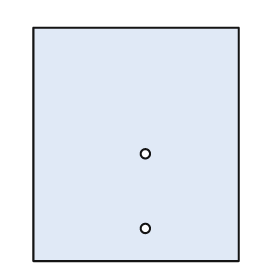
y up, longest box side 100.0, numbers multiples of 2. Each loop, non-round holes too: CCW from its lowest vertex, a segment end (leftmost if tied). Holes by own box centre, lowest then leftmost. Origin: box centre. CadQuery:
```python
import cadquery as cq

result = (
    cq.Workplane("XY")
    .moveTo(-44.0, -50.0)
    .lineTo(44.0, -50.0)
    .lineTo(44.0, 50.0)
    .lineTo(-44.0, 50.0)
    .close()
    .moveTo(4.0, -36.0)
    .circle(2.0)
    .moveTo(4.0, -4.0)
    .circle(2.0)
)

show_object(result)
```